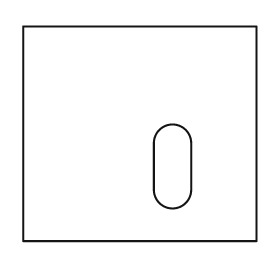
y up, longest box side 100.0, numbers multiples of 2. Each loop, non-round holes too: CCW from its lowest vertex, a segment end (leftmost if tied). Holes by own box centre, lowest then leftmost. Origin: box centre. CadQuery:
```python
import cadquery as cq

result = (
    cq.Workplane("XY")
    .moveTo(-50.0, -46.0)
    .lineTo(50.0, -46.0)
    .lineTo(50.0, 46.0)
    .lineTo(-50.0, 46.0)
    .close()
    .moveTo(6.0, -24.0)
    .threePointArc((14.0, -32.0), (22.0, -24.0))
    .lineTo(22.0, -4.0)
    .threePointArc((14.0, 4.0), (6.0, -4.0))
    .close()
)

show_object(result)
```